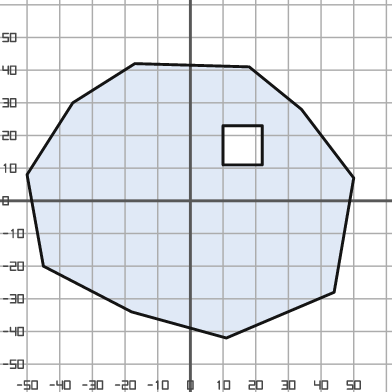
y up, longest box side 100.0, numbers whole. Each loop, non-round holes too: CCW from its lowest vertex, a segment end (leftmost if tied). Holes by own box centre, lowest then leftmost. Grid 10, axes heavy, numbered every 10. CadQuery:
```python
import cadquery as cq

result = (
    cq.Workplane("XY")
    .moveTo(11.0, -42.0)
    .lineTo(44.0, -28.0)
    .lineTo(50.0, 7.0)
    .lineTo(34.0, 28.0)
    .lineTo(18.0, 41.0)
    .lineTo(-17.0, 42.0)
    .lineTo(-36.0, 30.0)
    .lineTo(-50.0, 8.0)
    .lineTo(-45.0, -20.0)
    .lineTo(-18.0, -34.0)
    .close()
    .moveTo(10.0, 11.0)
    .lineTo(22.0, 11.0)
    .lineTo(22.0, 23.0)
    .lineTo(10.0, 23.0)
    .close()
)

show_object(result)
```